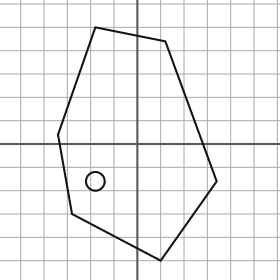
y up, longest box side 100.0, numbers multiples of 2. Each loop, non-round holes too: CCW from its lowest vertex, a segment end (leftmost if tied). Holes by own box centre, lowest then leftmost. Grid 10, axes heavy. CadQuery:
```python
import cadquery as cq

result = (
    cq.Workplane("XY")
    .moveTo(10.0, -50.0)
    .lineTo(34.0, -16.0)
    .lineTo(12.0, 44.0)
    .lineTo(-18.0, 50.0)
    .lineTo(-34.0, 4.0)
    .lineTo(-28.0, -30.0)
    .close()
    .moveTo(-18.0, -16.0)
    .circle(4.0)
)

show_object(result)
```